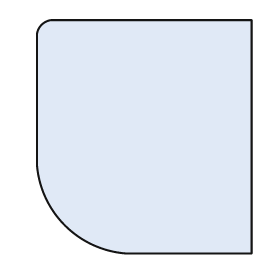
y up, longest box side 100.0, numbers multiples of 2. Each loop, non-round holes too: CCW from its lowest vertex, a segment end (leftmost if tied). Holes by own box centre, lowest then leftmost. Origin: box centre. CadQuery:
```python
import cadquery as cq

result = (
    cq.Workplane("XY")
    .moveTo(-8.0, -50.0)
    .lineTo(46.0, -50.0)
    .lineTo(46.0, 50.0)
    .lineTo(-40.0, 50.0)
    .threePointArc((-44.0, 48.0), (-46.0, 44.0))
    .lineTo(-46.0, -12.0)
    .threePointArc((-34.0, -38.0), (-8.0, -50.0))
    .close()
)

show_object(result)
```